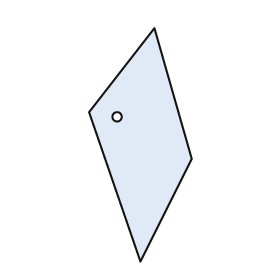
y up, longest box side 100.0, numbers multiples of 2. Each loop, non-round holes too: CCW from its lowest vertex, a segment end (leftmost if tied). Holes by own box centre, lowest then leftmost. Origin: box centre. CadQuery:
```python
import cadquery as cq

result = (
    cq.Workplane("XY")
    .moveTo(0.0, -50.0)
    .lineTo(22.0, -6.0)
    .lineTo(6.0, 50.0)
    .lineTo(-22.0, 14.0)
    .close()
    .moveTo(-10.0, 12.0)
    .circle(2.0)
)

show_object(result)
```